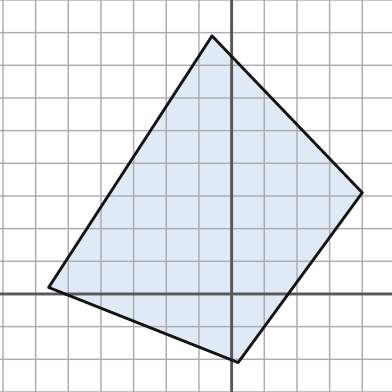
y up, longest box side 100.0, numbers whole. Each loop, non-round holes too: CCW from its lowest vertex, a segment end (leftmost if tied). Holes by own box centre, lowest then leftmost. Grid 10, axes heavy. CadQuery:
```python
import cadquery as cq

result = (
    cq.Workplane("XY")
    .moveTo(2.0, -21.0)
    .lineTo(40.0, 31.0)
    .lineTo(-6.0, 79.0)
    .lineTo(-56.0, 2.0)
    .close()
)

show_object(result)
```